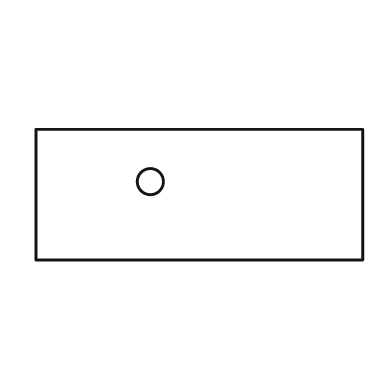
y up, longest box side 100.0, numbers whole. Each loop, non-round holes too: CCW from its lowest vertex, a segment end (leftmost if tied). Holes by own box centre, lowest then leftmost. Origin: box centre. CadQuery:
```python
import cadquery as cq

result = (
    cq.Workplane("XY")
    .moveTo(-50.0, -20.0)
    .lineTo(50.0, -20.0)
    .lineTo(50.0, 20.0)
    .lineTo(-50.0, 20.0)
    .close()
    .moveTo(-15.0, 4.0)
    .circle(4.0)
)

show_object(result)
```